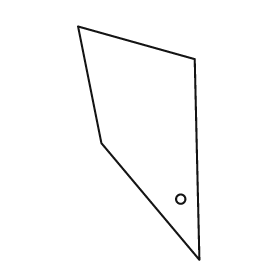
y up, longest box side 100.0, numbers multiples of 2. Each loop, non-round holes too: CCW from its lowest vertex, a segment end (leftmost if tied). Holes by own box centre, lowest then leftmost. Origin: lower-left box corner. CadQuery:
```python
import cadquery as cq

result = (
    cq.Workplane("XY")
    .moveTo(52.0, 0.0)
    .lineTo(50.0, 86.0)
    .lineTo(0.0, 100.0)
    .lineTo(10.0, 50.0)
    .close()
    .moveTo(44.0, 26.0)
    .circle(2.0)
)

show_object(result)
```